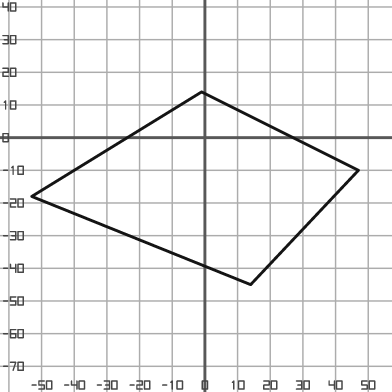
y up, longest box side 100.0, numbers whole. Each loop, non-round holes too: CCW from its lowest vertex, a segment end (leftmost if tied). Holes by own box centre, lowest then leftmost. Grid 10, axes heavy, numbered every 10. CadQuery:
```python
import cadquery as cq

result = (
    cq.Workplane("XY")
    .moveTo(14.0, -45.0)
    .lineTo(47.0, -10.0)
    .lineTo(-1.0, 14.0)
    .lineTo(-53.0, -18.0)
    .close()
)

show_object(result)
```